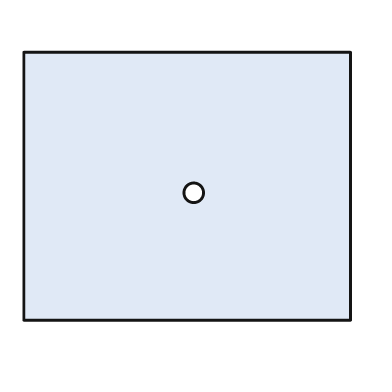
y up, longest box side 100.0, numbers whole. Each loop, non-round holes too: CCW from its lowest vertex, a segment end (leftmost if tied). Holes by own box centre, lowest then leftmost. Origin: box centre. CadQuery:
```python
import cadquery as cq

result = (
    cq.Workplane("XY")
    .moveTo(-50.0, -41.0)
    .lineTo(50.0, -41.0)
    .lineTo(50.0, 41.0)
    .lineTo(-50.0, 41.0)
    .close()
    .moveTo(2.0, -2.0)
    .circle(3.0)
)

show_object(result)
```